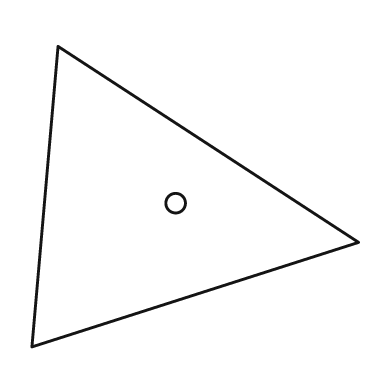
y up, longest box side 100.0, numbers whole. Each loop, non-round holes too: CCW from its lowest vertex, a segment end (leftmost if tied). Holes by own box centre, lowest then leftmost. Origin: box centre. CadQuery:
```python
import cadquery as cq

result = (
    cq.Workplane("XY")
    .moveTo(-50.0, -46.0)
    .lineTo(50.0, -14.0)
    .lineTo(-42.0, 46.0)
    .close()
    .moveTo(-6.0, -2.0)
    .circle(3.0)
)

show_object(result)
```